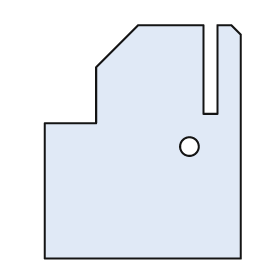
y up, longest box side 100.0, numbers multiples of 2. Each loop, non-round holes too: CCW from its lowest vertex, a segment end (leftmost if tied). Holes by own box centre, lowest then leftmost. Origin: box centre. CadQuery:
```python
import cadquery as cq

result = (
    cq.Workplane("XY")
    .moveTo(-42.0, -50.0)
    .lineTo(42.0, -50.0)
    .lineTo(42.0, 46.0)
    .lineTo(38.0, 50.0)
    .lineTo(32.0, 50.0)
    .lineTo(32.0, 12.0)
    .lineTo(26.0, 12.0)
    .lineTo(26.0, 50.0)
    .lineTo(-2.0, 50.0)
    .lineTo(-20.0, 32.0)
    .lineTo(-20.0, 8.0)
    .lineTo(-42.0, 8.0)
    .close()
    .moveTo(20.0, -2.0)
    .circle(4.0)
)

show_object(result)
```